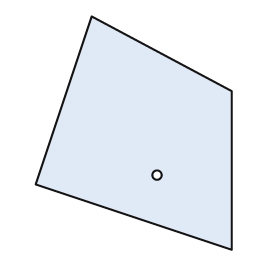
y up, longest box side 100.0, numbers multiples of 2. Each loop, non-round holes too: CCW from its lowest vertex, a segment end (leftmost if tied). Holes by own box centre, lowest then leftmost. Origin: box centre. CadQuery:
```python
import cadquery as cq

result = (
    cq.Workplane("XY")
    .moveTo(42.0, -50.0)
    .lineTo(42.0, 18.0)
    .lineTo(-18.0, 50.0)
    .lineTo(-42.0, -22.0)
    .close()
    .moveTo(10.0, -18.0)
    .circle(2.0)
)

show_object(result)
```